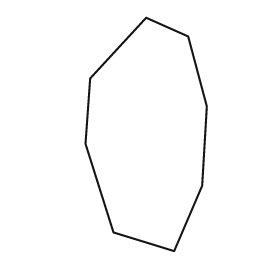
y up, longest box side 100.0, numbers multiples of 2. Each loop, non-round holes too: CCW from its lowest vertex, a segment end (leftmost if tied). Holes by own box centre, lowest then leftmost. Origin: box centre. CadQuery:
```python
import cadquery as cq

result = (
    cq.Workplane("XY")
    .moveTo(12.0, -50.0)
    .lineTo(24.0, -22.0)
    .lineTo(26.0, 12.0)
    .lineTo(18.0, 42.0)
    .lineTo(0.0, 50.0)
    .lineTo(-24.0, 24.0)
    .lineTo(-26.0, -4.0)
    .lineTo(-14.0, -42.0)
    .close()
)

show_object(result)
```